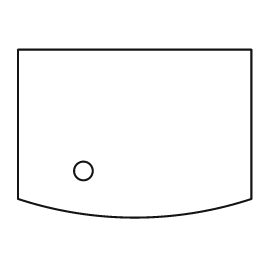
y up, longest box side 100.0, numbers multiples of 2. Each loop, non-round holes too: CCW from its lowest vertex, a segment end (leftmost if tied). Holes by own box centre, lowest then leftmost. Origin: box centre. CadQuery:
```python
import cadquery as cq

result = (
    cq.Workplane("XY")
    .moveTo(-50.0, -28.0)
    .threePointArc((0.0, -36.0), (50.0, -28.0))
    .lineTo(50.0, 36.0)
    .lineTo(-50.0, 36.0)
    .close()
    .moveTo(-22.0, -16.0)
    .circle(4.0)
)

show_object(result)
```